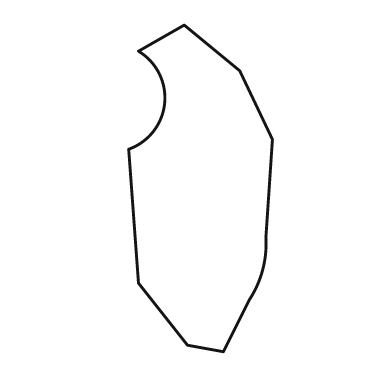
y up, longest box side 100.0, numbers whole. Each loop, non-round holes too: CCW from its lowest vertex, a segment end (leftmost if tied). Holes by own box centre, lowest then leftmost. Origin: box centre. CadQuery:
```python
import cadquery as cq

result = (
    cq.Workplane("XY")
    .moveTo(7.0, -50.0)
    .lineTo(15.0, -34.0)
    .threePointArc((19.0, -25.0), (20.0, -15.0))
    .lineTo(22.0, 15.0)
    .lineTo(12.0, 36.0)
    .lineTo(-5.0, 50.0)
    .lineTo(-19.0, 42.0)
    .threePointArc((-11.0, 26.0), (-22.0, 12.0))
    .lineTo(-19.0, -29.0)
    .lineTo(-4.0, -48.0)
    .close()
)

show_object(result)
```